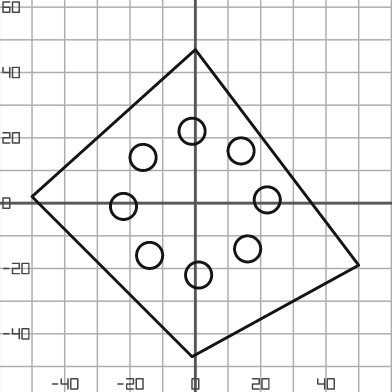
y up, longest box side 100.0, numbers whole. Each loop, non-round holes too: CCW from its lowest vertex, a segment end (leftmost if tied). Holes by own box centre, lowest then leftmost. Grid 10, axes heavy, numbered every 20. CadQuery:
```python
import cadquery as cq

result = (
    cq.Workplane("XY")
    .moveTo(-1.0, -47.0)
    .lineTo(50.0, -19.0)
    .lineTo(0.0, 47.0)
    .lineTo(-50.0, 2.0)
    .close()
    .moveTo(1.0, -22.0)
    .circle(4.0)
    .moveTo(-14.0, -16.0)
    .circle(4.0)
    .moveTo(16.0, -14.0)
    .circle(4.0)
    .moveTo(-22.0, -1.0)
    .circle(4.0)
    .moveTo(22.0, 1.0)
    .circle(4.0)
    .moveTo(-16.0, 14.0)
    .circle(4.0)
    .moveTo(14.0, 16.0)
    .circle(4.0)
    .moveTo(-1.0, 22.0)
    .circle(4.0)
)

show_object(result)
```